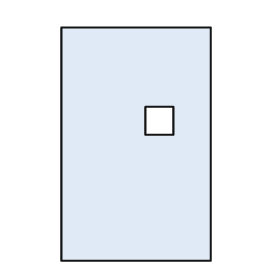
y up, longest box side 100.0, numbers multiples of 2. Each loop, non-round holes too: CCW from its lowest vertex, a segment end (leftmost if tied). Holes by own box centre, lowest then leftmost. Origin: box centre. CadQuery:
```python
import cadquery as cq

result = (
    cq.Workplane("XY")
    .moveTo(-32.0, -50.0)
    .lineTo(32.0, -50.0)
    .lineTo(32.0, 50.0)
    .lineTo(-32.0, 50.0)
    .close()
    .moveTo(4.0, 4.0)
    .lineTo(16.0, 4.0)
    .lineTo(16.0, 16.0)
    .lineTo(4.0, 16.0)
    .close()
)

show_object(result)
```